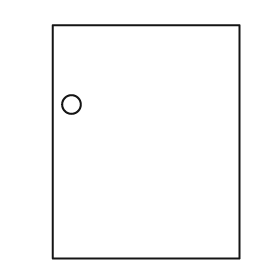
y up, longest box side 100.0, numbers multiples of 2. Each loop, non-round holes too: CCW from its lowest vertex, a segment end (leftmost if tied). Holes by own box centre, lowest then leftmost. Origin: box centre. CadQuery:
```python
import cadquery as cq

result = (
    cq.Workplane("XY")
    .moveTo(-40.0, -50.0)
    .lineTo(40.0, -50.0)
    .lineTo(40.0, 50.0)
    .lineTo(-40.0, 50.0)
    .close()
    .moveTo(-32.0, 16.0)
    .circle(4.0)
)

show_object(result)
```